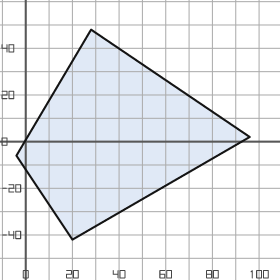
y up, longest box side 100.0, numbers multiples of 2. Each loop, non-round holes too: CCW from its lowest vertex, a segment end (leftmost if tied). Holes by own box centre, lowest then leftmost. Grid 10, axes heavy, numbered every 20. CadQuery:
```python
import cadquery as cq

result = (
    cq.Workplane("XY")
    .moveTo(20.0, -42.0)
    .lineTo(96.0, 2.0)
    .lineTo(28.0, 48.0)
    .lineTo(-4.0, -6.0)
    .close()
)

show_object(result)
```